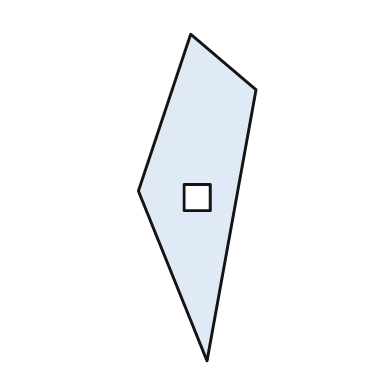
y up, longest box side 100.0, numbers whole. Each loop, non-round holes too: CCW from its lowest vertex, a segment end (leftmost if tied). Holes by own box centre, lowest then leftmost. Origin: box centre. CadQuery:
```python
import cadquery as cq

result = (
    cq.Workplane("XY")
    .moveTo(3.0, -50.0)
    .lineTo(18.0, 33.0)
    .lineTo(-2.0, 50.0)
    .lineTo(-18.0, 2.0)
    .close()
    .moveTo(-4.0, -4.0)
    .lineTo(4.0, -4.0)
    .lineTo(4.0, 4.0)
    .lineTo(-4.0, 4.0)
    .close()
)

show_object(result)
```